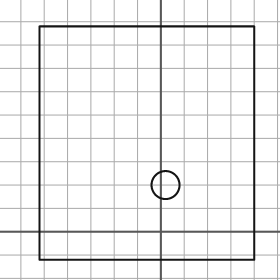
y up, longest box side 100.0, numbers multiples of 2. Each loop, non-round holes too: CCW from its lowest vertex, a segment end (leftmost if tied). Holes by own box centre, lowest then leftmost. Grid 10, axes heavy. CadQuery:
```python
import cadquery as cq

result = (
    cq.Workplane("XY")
    .moveTo(-52.0, -12.0)
    .lineTo(40.0, -12.0)
    .lineTo(40.0, 88.0)
    .lineTo(-52.0, 88.0)
    .close()
    .moveTo(2.0, 20.0)
    .circle(6.0)
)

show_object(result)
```